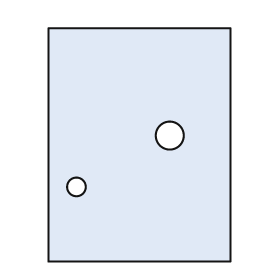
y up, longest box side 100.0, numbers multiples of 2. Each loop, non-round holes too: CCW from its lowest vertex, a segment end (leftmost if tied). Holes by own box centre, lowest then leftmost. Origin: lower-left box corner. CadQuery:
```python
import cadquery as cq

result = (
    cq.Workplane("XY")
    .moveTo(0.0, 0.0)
    .lineTo(78.0, 0.0)
    .lineTo(78.0, 100.0)
    .lineTo(0.0, 100.0)
    .close()
    .moveTo(12.0, 32.0)
    .circle(4.0)
    .moveTo(52.0, 54.0)
    .circle(6.0)
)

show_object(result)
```